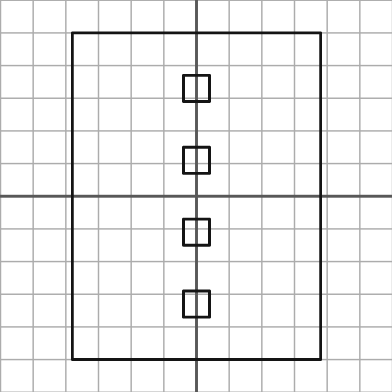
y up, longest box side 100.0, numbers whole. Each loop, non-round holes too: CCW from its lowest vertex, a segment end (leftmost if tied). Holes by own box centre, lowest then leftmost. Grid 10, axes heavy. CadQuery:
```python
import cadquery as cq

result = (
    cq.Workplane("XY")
    .moveTo(-38.0, -50.0)
    .lineTo(38.0, -50.0)
    .lineTo(38.0, 50.0)
    .lineTo(-38.0, 50.0)
    .close()
    .moveTo(-4.0, -37.0)
    .lineTo(4.0, -37.0)
    .lineTo(4.0, -29.0)
    .lineTo(-4.0, -29.0)
    .close()
    .moveTo(-4.0, -15.0)
    .lineTo(4.0, -15.0)
    .lineTo(4.0, -7.0)
    .lineTo(-4.0, -7.0)
    .close()
    .moveTo(-4.0, 7.0)
    .lineTo(4.0, 7.0)
    .lineTo(4.0, 15.0)
    .lineTo(-4.0, 15.0)
    .close()
    .moveTo(-4.0, 29.0)
    .lineTo(4.0, 29.0)
    .lineTo(4.0, 37.0)
    .lineTo(-4.0, 37.0)
    .close()
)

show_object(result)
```